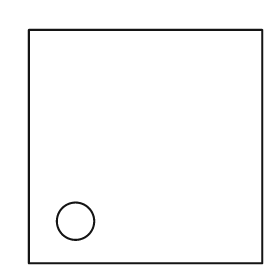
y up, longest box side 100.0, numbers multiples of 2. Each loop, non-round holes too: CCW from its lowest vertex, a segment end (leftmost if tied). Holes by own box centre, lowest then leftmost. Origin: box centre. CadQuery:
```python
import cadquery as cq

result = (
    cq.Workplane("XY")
    .moveTo(-50.0, -50.0)
    .lineTo(50.0, -50.0)
    .lineTo(50.0, 50.0)
    .lineTo(-50.0, 50.0)
    .close()
    .moveTo(-30.0, -32.0)
    .circle(8.0)
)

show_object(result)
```